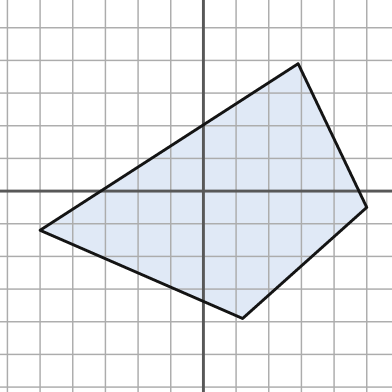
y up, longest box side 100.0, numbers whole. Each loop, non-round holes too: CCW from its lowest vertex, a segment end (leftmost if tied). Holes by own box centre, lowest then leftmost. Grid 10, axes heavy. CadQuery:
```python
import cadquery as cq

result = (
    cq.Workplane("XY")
    .moveTo(12.0, -39.0)
    .lineTo(50.0, -5.0)
    .lineTo(29.0, 39.0)
    .lineTo(-50.0, -12.0)
    .close()
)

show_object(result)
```